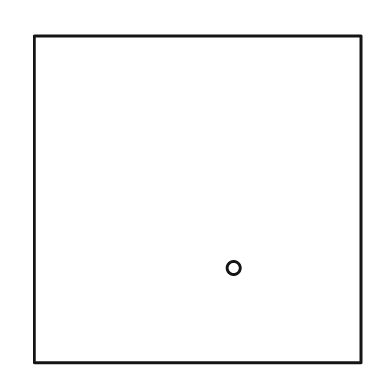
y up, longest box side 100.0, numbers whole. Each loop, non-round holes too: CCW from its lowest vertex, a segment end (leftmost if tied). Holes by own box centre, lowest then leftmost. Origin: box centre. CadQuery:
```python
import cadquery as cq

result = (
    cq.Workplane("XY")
    .moveTo(-50.0, -50.0)
    .lineTo(50.0, -50.0)
    .lineTo(50.0, 50.0)
    .lineTo(-50.0, 50.0)
    .close()
    .moveTo(11.0, -21.0)
    .circle(2.0)
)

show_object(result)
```